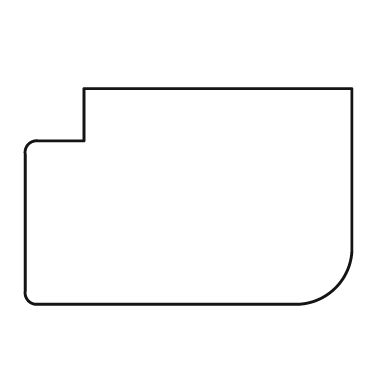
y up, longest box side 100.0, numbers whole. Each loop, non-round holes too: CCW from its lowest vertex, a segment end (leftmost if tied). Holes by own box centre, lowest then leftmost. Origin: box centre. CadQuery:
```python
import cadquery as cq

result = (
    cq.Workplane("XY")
    .moveTo(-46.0, -33.0)
    .lineTo(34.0, -33.0)
    .threePointArc((45.0, -28.0), (50.0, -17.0))
    .lineTo(50.0, 33.0)
    .lineTo(-32.0, 33.0)
    .lineTo(-32.0, 17.0)
    .lineTo(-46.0, 17.0)
    .threePointArc((-49.0, 16.0), (-50.0, 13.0))
    .lineTo(-50.0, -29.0)
    .threePointArc((-49.0, -32.0), (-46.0, -33.0))
    .close()
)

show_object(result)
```